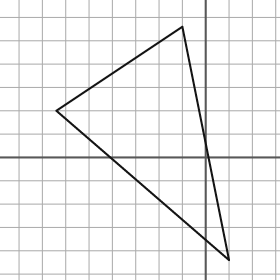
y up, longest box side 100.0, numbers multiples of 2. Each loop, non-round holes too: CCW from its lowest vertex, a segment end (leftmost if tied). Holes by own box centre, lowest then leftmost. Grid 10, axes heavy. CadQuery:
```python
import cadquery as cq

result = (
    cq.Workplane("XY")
    .moveTo(10.0, -44.0)
    .lineTo(-10.0, 56.0)
    .lineTo(-64.0, 20.0)
    .close()
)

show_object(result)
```